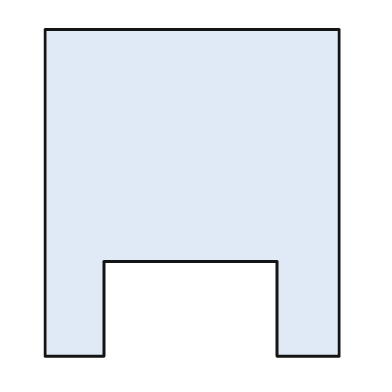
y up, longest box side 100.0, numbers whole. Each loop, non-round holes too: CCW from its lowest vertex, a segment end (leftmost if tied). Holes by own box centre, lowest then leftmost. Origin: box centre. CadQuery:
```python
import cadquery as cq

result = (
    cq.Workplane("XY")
    .moveTo(-45.0, -50.0)
    .lineTo(-27.0, -50.0)
    .lineTo(-27.0, -21.0)
    .lineTo(26.0, -21.0)
    .lineTo(26.0, -50.0)
    .lineTo(45.0, -50.0)
    .lineTo(45.0, 50.0)
    .lineTo(-45.0, 50.0)
    .close()
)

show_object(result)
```